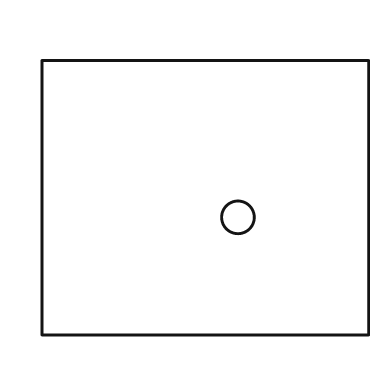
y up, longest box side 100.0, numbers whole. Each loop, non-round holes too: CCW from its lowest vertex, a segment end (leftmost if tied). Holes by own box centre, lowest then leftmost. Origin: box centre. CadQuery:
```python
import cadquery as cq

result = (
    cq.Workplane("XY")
    .moveTo(-50.0, -42.0)
    .lineTo(50.0, -42.0)
    .lineTo(50.0, 42.0)
    .lineTo(-50.0, 42.0)
    .close()
    .moveTo(10.0, -6.0)
    .circle(5.0)
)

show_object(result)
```